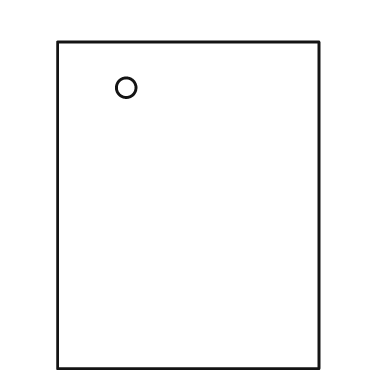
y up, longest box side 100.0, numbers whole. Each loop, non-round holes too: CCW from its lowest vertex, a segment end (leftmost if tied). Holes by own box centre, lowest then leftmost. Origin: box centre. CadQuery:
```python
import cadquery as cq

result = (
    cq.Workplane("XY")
    .moveTo(-40.0, -50.0)
    .lineTo(40.0, -50.0)
    .lineTo(40.0, 50.0)
    .lineTo(-40.0, 50.0)
    .close()
    .moveTo(-19.0, 36.0)
    .circle(3.0)
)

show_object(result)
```